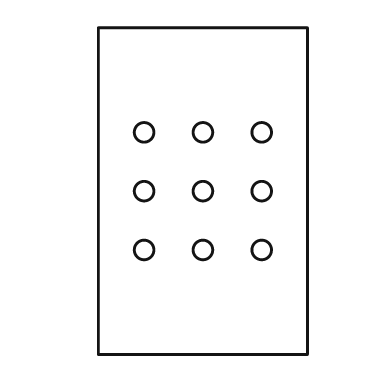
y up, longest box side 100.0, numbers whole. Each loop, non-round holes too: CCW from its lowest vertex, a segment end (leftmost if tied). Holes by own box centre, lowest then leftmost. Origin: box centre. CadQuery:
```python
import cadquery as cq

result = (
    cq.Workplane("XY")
    .moveTo(-32.0, -50.0)
    .lineTo(32.0, -50.0)
    .lineTo(32.0, 50.0)
    .lineTo(-32.0, 50.0)
    .close()
    .moveTo(-18.0, -18.0)
    .circle(3.0)
    .moveTo(0.0, -18.0)
    .circle(3.0)
    .moveTo(18.0, -18.0)
    .circle(3.0)
    .moveTo(-18.0, 0.0)
    .circle(3.0)
    .moveTo(0.0, 0.0)
    .circle(3.0)
    .moveTo(18.0, 0.0)
    .circle(3.0)
    .moveTo(-18.0, 18.0)
    .circle(3.0)
    .moveTo(0.0, 18.0)
    .circle(3.0)
    .moveTo(18.0, 18.0)
    .circle(3.0)
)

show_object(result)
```